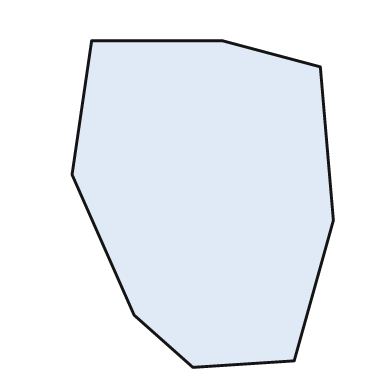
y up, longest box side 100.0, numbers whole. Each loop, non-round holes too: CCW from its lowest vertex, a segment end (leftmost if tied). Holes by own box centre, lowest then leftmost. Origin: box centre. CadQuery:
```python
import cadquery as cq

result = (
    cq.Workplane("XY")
    .moveTo(-3.0, -50.0)
    .lineTo(28.0, -48.0)
    .lineTo(40.0, -5.0)
    .lineTo(36.0, 42.0)
    .lineTo(6.0, 50.0)
    .lineTo(-34.0, 50.0)
    .lineTo(-40.0, 9.0)
    .lineTo(-21.0, -34.0)
    .close()
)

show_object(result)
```